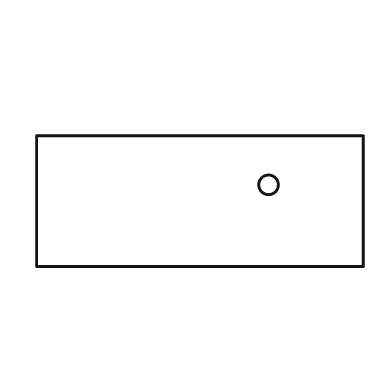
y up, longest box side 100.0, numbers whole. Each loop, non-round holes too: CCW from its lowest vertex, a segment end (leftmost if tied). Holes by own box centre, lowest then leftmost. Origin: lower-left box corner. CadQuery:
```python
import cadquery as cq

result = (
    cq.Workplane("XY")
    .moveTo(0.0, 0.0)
    .lineTo(100.0, 0.0)
    .lineTo(100.0, 40.0)
    .lineTo(0.0, 40.0)
    .close()
    .moveTo(71.0, 25.0)
    .circle(3.0)
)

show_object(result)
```